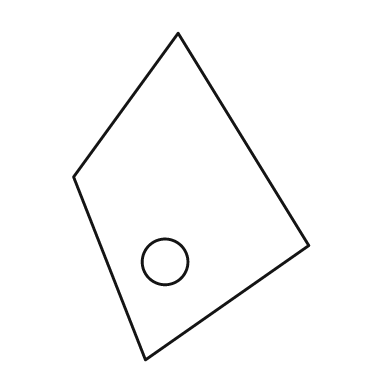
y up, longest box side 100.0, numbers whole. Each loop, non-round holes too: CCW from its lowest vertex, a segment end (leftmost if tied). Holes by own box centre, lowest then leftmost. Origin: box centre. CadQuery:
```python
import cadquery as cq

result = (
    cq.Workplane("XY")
    .moveTo(-14.0, -50.0)
    .lineTo(36.0, -15.0)
    .lineTo(-4.0, 50.0)
    .lineTo(-36.0, 6.0)
    .close()
    .moveTo(-8.0, -20.0)
    .circle(7.0)
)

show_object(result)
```